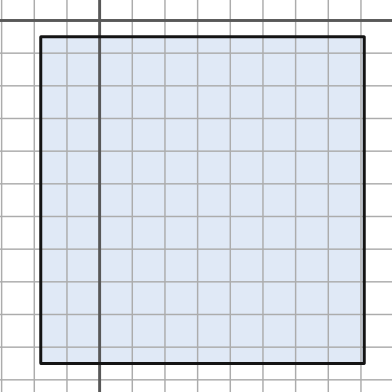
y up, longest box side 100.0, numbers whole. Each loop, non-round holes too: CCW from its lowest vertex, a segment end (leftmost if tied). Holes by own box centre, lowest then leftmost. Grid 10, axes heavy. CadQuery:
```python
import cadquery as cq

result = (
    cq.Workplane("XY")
    .moveTo(-18.0, -105.0)
    .lineTo(81.0, -105.0)
    .lineTo(81.0, -5.0)
    .lineTo(-18.0, -5.0)
    .close()
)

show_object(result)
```